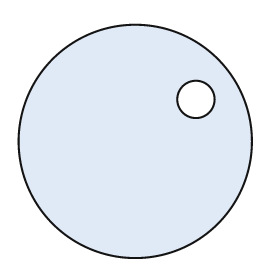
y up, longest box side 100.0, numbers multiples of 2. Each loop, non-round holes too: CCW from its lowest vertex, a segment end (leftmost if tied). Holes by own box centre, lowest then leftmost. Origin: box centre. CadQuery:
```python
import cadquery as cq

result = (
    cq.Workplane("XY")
    .moveTo(0.0, 0.0)
    .circle(50.0)
    .moveTo(26.0, 18.0)
    .circle(8.0)
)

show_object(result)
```